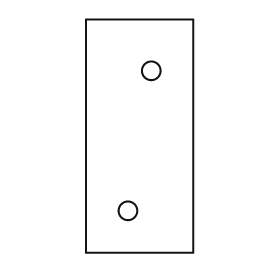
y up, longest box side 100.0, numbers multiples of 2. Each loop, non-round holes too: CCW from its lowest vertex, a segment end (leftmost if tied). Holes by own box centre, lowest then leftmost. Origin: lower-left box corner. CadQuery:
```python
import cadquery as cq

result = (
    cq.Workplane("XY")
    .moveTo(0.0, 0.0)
    .lineTo(46.0, 0.0)
    .lineTo(46.0, 100.0)
    .lineTo(0.0, 100.0)
    .close()
    .moveTo(18.0, 18.0)
    .circle(4.0)
    .moveTo(28.0, 78.0)
    .circle(4.0)
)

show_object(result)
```